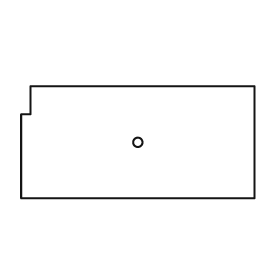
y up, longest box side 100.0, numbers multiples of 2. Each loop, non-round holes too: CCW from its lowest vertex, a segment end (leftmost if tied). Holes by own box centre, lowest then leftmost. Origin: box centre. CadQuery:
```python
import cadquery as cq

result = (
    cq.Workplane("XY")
    .moveTo(-50.0, -24.0)
    .lineTo(50.0, -24.0)
    .lineTo(50.0, 24.0)
    .lineTo(-46.0, 24.0)
    .lineTo(-46.0, 12.0)
    .lineTo(-50.0, 12.0)
    .close()
    .moveTo(0.0, 0.0)
    .circle(2.0)
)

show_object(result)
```